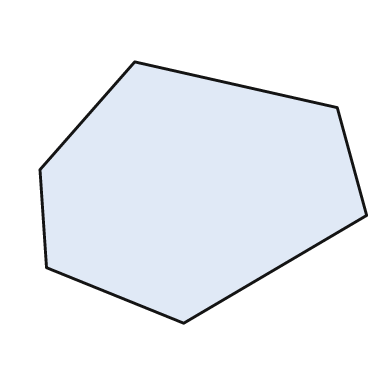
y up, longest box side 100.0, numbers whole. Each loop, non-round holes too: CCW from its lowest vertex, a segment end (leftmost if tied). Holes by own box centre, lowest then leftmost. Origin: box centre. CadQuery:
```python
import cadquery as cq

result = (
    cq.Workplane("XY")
    .moveTo(-6.0, -40.0)
    .lineTo(50.0, -7.0)
    .lineTo(41.0, 26.0)
    .lineTo(-21.0, 40.0)
    .lineTo(-50.0, 7.0)
    .lineTo(-48.0, -23.0)
    .close()
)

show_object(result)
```